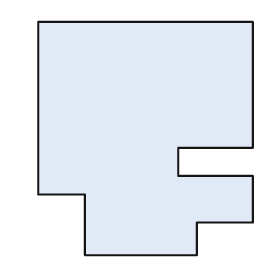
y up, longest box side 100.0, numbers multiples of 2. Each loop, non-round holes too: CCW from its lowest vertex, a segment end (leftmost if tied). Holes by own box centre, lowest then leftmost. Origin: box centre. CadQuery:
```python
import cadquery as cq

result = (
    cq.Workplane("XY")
    .moveTo(-26.0, -50.0)
    .lineTo(22.0, -50.0)
    .lineTo(22.0, -36.0)
    .lineTo(46.0, -36.0)
    .lineTo(46.0, -16.0)
    .lineTo(14.0, -16.0)
    .lineTo(14.0, -4.0)
    .lineTo(46.0, -4.0)
    .lineTo(46.0, 50.0)
    .lineTo(-46.0, 50.0)
    .lineTo(-46.0, -24.0)
    .lineTo(-26.0, -24.0)
    .close()
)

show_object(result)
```